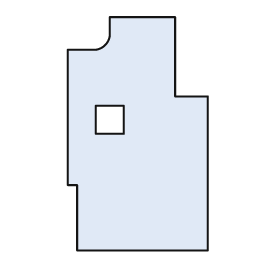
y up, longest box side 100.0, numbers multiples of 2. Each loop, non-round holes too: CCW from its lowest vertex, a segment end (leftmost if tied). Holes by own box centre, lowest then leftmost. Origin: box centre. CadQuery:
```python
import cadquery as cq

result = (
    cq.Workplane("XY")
    .moveTo(-26.0, -50.0)
    .lineTo(30.0, -50.0)
    .lineTo(30.0, 16.0)
    .lineTo(16.0, 16.0)
    .lineTo(16.0, 50.0)
    .lineTo(-12.0, 50.0)
    .lineTo(-12.0, 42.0)
    .threePointArc((-14.0, 38.0), (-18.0, 36.0))
    .lineTo(-30.0, 36.0)
    .lineTo(-30.0, -22.0)
    .lineTo(-26.0, -22.0)
    .close()
    .moveTo(-18.0, 0.0)
    .lineTo(-6.0, 0.0)
    .lineTo(-6.0, 12.0)
    .lineTo(-18.0, 12.0)
    .close()
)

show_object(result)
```